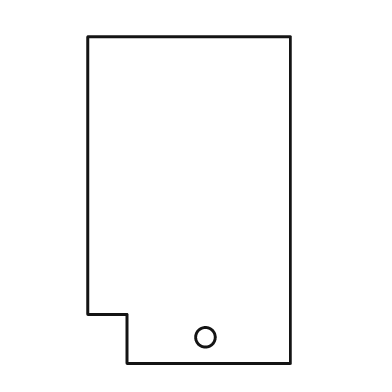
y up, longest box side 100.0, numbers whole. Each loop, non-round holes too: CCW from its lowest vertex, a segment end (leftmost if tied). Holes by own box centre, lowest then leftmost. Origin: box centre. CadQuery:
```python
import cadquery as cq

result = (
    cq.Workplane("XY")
    .moveTo(-19.0, -50.0)
    .lineTo(31.0, -50.0)
    .lineTo(31.0, 50.0)
    .lineTo(-31.0, 50.0)
    .lineTo(-31.0, -35.0)
    .lineTo(-19.0, -35.0)
    .close()
    .moveTo(5.0, -42.0)
    .circle(3.0)
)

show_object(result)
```